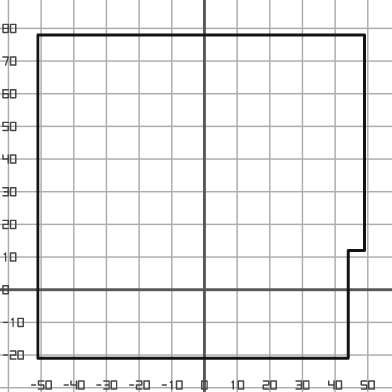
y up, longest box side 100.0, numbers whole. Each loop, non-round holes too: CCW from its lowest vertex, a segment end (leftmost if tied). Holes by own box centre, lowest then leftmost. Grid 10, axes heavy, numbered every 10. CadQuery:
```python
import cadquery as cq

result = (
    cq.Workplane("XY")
    .moveTo(-51.0, -21.0)
    .lineTo(44.0, -21.0)
    .lineTo(44.0, 12.0)
    .lineTo(49.0, 12.0)
    .lineTo(49.0, 78.0)
    .lineTo(-51.0, 78.0)
    .close()
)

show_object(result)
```